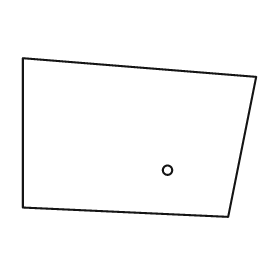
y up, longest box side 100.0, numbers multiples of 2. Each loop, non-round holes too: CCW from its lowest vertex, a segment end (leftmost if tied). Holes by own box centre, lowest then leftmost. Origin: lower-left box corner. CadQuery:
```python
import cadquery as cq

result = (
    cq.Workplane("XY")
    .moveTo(88.0, 0.0)
    .lineTo(100.0, 60.0)
    .lineTo(0.0, 68.0)
    .lineTo(0.0, 4.0)
    .close()
    .moveTo(62.0, 20.0)
    .circle(2.0)
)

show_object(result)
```